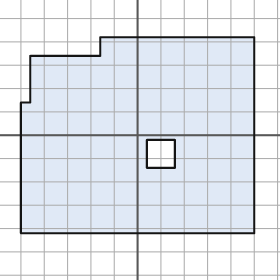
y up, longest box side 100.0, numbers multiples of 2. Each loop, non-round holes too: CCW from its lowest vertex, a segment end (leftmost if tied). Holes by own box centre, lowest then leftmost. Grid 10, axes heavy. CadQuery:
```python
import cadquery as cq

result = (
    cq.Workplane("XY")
    .moveTo(-50.0, -42.0)
    .lineTo(50.0, -42.0)
    .lineTo(50.0, 42.0)
    .lineTo(-16.0, 42.0)
    .lineTo(-16.0, 34.0)
    .lineTo(-46.0, 34.0)
    .lineTo(-46.0, 14.0)
    .lineTo(-50.0, 14.0)
    .close()
    .moveTo(4.0, -14.0)
    .lineTo(16.0, -14.0)
    .lineTo(16.0, -2.0)
    .lineTo(4.0, -2.0)
    .close()
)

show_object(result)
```